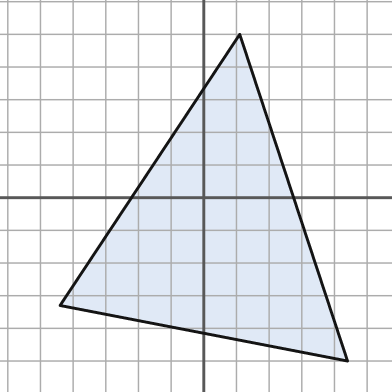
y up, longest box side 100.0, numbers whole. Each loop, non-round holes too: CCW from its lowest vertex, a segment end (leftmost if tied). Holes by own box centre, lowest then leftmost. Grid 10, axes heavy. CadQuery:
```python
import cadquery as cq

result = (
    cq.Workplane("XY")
    .moveTo(44.0, -50.0)
    .lineTo(11.0, 50.0)
    .lineTo(-44.0, -33.0)
    .close()
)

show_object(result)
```